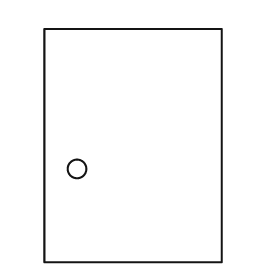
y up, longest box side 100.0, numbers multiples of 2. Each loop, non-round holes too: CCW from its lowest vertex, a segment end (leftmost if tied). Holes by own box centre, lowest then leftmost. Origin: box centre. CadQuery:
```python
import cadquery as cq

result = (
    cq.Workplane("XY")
    .moveTo(-38.0, -50.0)
    .lineTo(38.0, -50.0)
    .lineTo(38.0, 50.0)
    .lineTo(-38.0, 50.0)
    .close()
    .moveTo(-24.0, -10.0)
    .circle(4.0)
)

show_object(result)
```